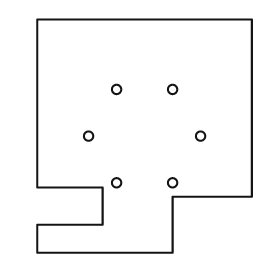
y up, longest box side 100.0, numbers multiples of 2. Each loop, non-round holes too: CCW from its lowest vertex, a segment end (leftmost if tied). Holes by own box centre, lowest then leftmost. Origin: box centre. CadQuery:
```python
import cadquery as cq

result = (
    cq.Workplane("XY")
    .moveTo(-46.0, -50.0)
    .lineTo(12.0, -50.0)
    .lineTo(12.0, -26.0)
    .lineTo(46.0, -26.0)
    .lineTo(46.0, 50.0)
    .lineTo(-46.0, 50.0)
    .lineTo(-46.0, -22.0)
    .lineTo(-18.0, -22.0)
    .lineTo(-18.0, -38.0)
    .lineTo(-46.0, -38.0)
    .close()
    .moveTo(-12.0, -20.0)
    .circle(2.0)
    .moveTo(12.0, -20.0)
    .circle(2.0)
    .moveTo(-24.0, 0.0)
    .circle(2.0)
    .moveTo(24.0, 0.0)
    .circle(2.0)
    .moveTo(-12.0, 20.0)
    .circle(2.0)
    .moveTo(12.0, 20.0)
    .circle(2.0)
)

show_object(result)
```